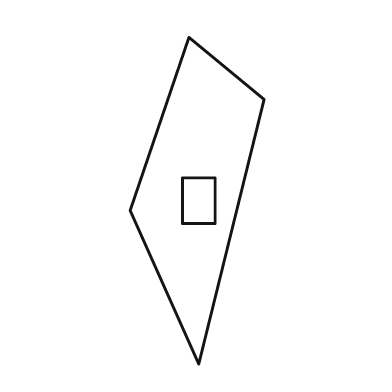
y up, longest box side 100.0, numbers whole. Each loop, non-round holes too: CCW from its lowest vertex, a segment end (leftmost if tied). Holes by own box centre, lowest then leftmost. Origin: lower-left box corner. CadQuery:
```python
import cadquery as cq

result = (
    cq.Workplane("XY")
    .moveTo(21.0, 0.0)
    .lineTo(41.0, 81.0)
    .lineTo(18.0, 100.0)
    .lineTo(0.0, 47.0)
    .close()
    .moveTo(16.0, 43.0)
    .lineTo(26.0, 43.0)
    .lineTo(26.0, 57.0)
    .lineTo(16.0, 57.0)
    .close()
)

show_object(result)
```